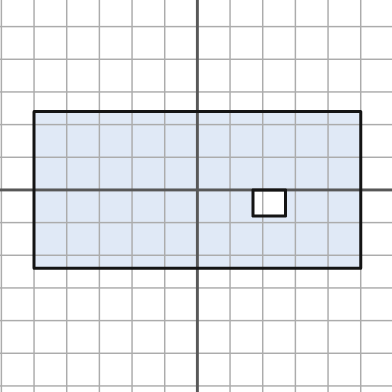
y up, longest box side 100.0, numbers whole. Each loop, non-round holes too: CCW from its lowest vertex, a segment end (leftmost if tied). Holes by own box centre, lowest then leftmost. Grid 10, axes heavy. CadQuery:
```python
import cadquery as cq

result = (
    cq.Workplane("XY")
    .moveTo(-50.0, -24.0)
    .lineTo(50.0, -24.0)
    .lineTo(50.0, 24.0)
    .lineTo(-50.0, 24.0)
    .close()
    .moveTo(17.0, -8.0)
    .lineTo(27.0, -8.0)
    .lineTo(27.0, 0.0)
    .lineTo(17.0, 0.0)
    .close()
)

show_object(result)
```